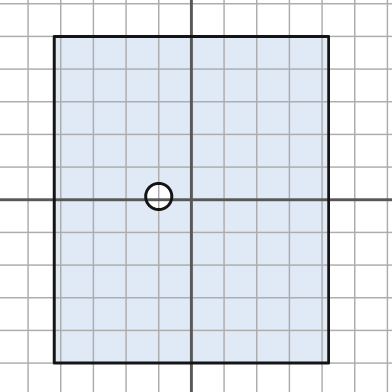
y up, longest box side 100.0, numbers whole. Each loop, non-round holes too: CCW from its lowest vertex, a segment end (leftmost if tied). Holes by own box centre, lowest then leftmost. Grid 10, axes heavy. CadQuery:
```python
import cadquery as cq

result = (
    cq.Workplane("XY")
    .moveTo(-42.0, -50.0)
    .lineTo(42.0, -50.0)
    .lineTo(42.0, 50.0)
    .lineTo(-42.0, 50.0)
    .close()
    .moveTo(-10.0, 1.0)
    .circle(4.0)
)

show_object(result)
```